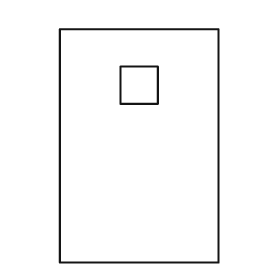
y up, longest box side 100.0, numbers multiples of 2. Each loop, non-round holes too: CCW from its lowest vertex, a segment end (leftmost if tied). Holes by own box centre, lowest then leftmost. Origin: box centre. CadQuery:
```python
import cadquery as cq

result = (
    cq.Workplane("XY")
    .moveTo(-34.0, -50.0)
    .lineTo(34.0, -50.0)
    .lineTo(34.0, 50.0)
    .lineTo(-34.0, 50.0)
    .close()
    .moveTo(-8.0, 18.0)
    .lineTo(8.0, 18.0)
    .lineTo(8.0, 34.0)
    .lineTo(-8.0, 34.0)
    .close()
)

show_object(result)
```